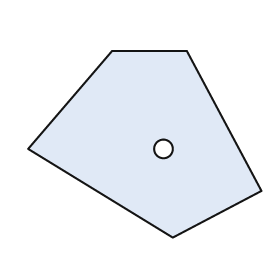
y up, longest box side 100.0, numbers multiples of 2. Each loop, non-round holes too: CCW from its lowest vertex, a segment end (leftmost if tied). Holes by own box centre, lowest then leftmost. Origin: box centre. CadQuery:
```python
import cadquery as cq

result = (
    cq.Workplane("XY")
    .moveTo(12.0, -40.0)
    .lineTo(50.0, -20.0)
    .lineTo(18.0, 40.0)
    .lineTo(-14.0, 40.0)
    .lineTo(-50.0, -2.0)
    .close()
    .moveTo(8.0, -2.0)
    .circle(4.0)
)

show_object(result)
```